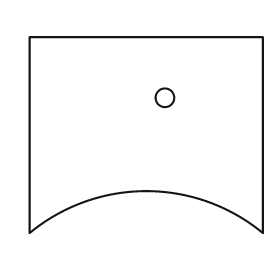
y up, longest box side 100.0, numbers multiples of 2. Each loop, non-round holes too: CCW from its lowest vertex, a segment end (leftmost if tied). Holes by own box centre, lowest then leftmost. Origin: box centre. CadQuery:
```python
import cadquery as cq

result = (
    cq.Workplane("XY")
    .moveTo(-50.0, -42.0)
    .threePointArc((0.0, -24.0), (50.0, -42.0))
    .lineTo(50.0, 42.0)
    .lineTo(-50.0, 42.0)
    .close()
    .moveTo(8.0, 16.0)
    .circle(4.0)
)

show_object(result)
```